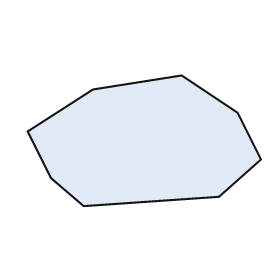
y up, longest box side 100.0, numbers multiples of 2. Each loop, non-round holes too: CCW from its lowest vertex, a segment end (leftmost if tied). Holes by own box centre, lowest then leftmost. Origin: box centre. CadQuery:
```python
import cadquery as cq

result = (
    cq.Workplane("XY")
    .moveTo(-26.0, -28.0)
    .lineTo(32.0, -24.0)
    .lineTo(50.0, -8.0)
    .lineTo(40.0, 12.0)
    .lineTo(16.0, 28.0)
    .lineTo(-22.0, 22.0)
    .lineTo(-50.0, 4.0)
    .lineTo(-40.0, -16.0)
    .close()
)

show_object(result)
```